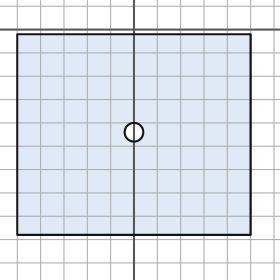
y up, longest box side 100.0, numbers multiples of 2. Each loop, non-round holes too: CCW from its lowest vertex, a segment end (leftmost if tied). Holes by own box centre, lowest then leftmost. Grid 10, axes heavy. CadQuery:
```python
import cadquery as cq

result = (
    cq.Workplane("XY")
    .moveTo(-50.0, -88.0)
    .lineTo(50.0, -88.0)
    .lineTo(50.0, -2.0)
    .lineTo(-50.0, -2.0)
    .close()
    .moveTo(0.0, -44.0)
    .circle(4.0)
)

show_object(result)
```